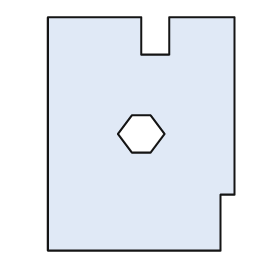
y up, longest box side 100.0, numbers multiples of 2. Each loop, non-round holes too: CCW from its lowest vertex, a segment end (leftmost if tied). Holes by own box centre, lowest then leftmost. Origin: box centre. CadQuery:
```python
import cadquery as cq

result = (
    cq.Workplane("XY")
    .moveTo(-40.0, -50.0)
    .lineTo(34.0, -50.0)
    .lineTo(34.0, -26.0)
    .lineTo(40.0, -26.0)
    .lineTo(40.0, 50.0)
    .lineTo(12.0, 50.0)
    .lineTo(12.0, 34.0)
    .lineTo(0.0, 34.0)
    .lineTo(0.0, 50.0)
    .lineTo(-40.0, 50.0)
    .close()
    .moveTo(-4.0, -8.0)
    .lineTo(4.0, -8.0)
    .lineTo(10.0, 0.0)
    .lineTo(4.0, 8.0)
    .lineTo(-4.0, 8.0)
    .lineTo(-10.0, 0.0)
    .close()
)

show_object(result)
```